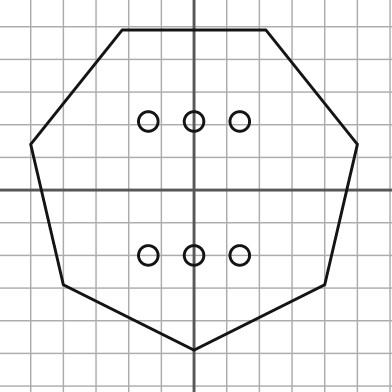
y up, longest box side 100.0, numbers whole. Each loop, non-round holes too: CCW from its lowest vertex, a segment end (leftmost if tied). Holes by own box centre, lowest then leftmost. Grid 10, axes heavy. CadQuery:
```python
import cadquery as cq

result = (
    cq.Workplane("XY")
    .moveTo(0.0, -49.0)
    .lineTo(40.0, -29.0)
    .lineTo(50.0, 14.0)
    .lineTo(22.0, 49.0)
    .lineTo(-22.0, 49.0)
    .lineTo(-50.0, 14.0)
    .lineTo(-40.0, -29.0)
    .close()
    .moveTo(-14.0, -20.0)
    .circle(3.0)
    .moveTo(0.0, -20.0)
    .circle(3.0)
    .moveTo(14.0, -20.0)
    .circle(3.0)
    .moveTo(-14.0, 21.0)
    .circle(3.0)
    .moveTo(0.0, 21.0)
    .circle(3.0)
    .moveTo(14.0, 21.0)
    .circle(3.0)
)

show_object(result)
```